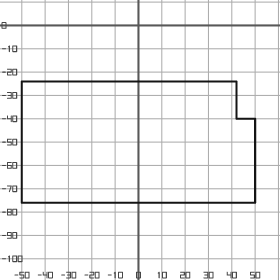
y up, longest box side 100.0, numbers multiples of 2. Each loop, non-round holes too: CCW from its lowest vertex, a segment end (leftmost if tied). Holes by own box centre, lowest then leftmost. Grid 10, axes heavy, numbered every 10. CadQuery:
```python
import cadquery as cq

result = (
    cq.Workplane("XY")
    .moveTo(-50.0, -76.0)
    .lineTo(50.0, -76.0)
    .lineTo(50.0, -40.0)
    .lineTo(42.0, -40.0)
    .lineTo(42.0, -24.0)
    .lineTo(-50.0, -24.0)
    .close()
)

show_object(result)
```